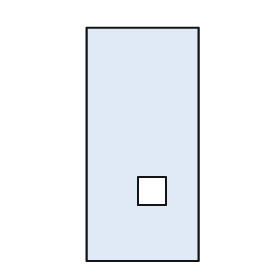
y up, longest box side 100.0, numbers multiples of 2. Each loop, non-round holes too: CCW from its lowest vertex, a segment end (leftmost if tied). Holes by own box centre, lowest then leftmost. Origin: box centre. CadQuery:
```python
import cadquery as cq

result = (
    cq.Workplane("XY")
    .moveTo(-24.0, -50.0)
    .lineTo(24.0, -50.0)
    .lineTo(24.0, 50.0)
    .lineTo(-24.0, 50.0)
    .close()
    .moveTo(-2.0, -26.0)
    .lineTo(10.0, -26.0)
    .lineTo(10.0, -14.0)
    .lineTo(-2.0, -14.0)
    .close()
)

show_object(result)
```